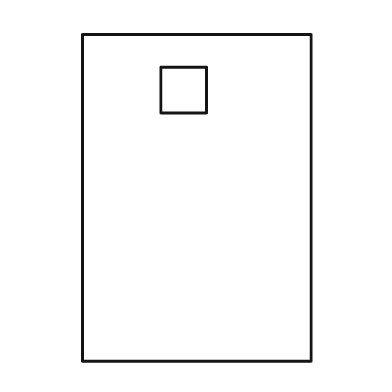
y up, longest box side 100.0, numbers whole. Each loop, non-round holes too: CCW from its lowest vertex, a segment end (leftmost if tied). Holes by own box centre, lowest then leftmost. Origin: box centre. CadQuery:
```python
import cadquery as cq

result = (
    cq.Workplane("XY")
    .moveTo(-35.0, -50.0)
    .lineTo(35.0, -50.0)
    .lineTo(35.0, 50.0)
    .lineTo(-35.0, 50.0)
    .close()
    .moveTo(-11.0, 26.0)
    .lineTo(3.0, 26.0)
    .lineTo(3.0, 40.0)
    .lineTo(-11.0, 40.0)
    .close()
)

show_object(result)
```